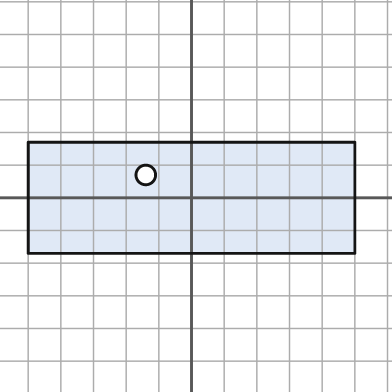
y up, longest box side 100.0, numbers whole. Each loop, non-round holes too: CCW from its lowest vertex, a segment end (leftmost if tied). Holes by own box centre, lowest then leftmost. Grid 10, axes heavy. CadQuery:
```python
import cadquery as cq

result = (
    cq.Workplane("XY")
    .moveTo(-50.0, -17.0)
    .lineTo(50.0, -17.0)
    .lineTo(50.0, 17.0)
    .lineTo(-50.0, 17.0)
    .close()
    .moveTo(-14.0, 7.0)
    .circle(3.0)
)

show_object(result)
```